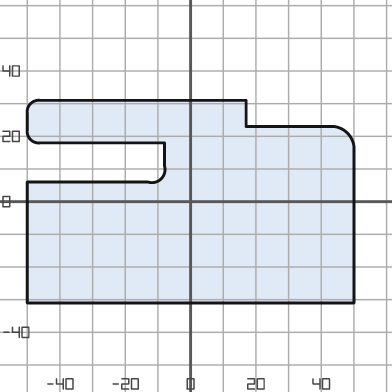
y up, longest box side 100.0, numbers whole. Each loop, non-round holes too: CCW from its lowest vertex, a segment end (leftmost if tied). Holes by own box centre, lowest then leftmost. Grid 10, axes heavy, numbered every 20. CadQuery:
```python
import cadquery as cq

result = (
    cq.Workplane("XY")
    .moveTo(-50.0, -31.0)
    .lineTo(50.0, -31.0)
    .lineTo(50.0, 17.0)
    .threePointArc((48.0, 21.0), (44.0, 23.0))
    .lineTo(17.0, 23.0)
    .lineTo(17.0, 31.0)
    .lineTo(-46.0, 31.0)
    .threePointArc((-49.0, 30.0), (-50.0, 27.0))
    .lineTo(-50.0, 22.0)
    .threePointArc((-49.0, 19.0), (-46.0, 18.0))
    .lineTo(-8.0, 18.0)
    .lineTo(-8.0, 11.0)
    .threePointArc((-9.0, 7.0), (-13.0, 6.0))
    .lineTo(-50.0, 6.0)
    .close()
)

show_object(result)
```